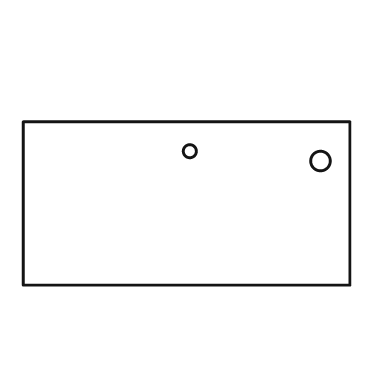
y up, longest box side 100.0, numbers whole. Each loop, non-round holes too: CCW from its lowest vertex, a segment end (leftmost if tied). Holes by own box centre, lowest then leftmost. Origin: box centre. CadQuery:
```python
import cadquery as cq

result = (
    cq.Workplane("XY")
    .moveTo(-50.0, -25.0)
    .lineTo(50.0, -25.0)
    .lineTo(50.0, 25.0)
    .lineTo(-50.0, 25.0)
    .close()
    .moveTo(41.0, 13.0)
    .circle(3.0)
    .moveTo(1.0, 16.0)
    .circle(2.0)
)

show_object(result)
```